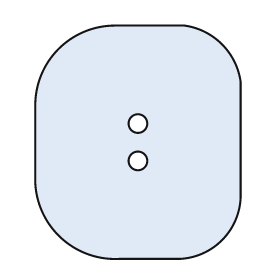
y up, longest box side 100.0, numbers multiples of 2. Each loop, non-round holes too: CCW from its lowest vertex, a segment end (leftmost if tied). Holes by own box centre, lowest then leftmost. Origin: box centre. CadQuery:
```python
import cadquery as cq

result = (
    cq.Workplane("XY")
    .moveTo(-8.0, -50.0)
    .lineTo(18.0, -50.0)
    .threePointArc((36.0, -42.0), (44.0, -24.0))
    .lineTo(44.0, 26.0)
    .threePointArc((36.0, 42.0), (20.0, 50.0))
    .lineTo(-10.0, 50.0)
    .threePointArc((-34.0, 40.0), (-44.0, 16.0))
    .lineTo(-44.0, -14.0)
    .threePointArc((-34.0, -40.0), (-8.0, -50.0))
    .close()
    .moveTo(0.0, -8.0)
    .circle(4.0)
    .moveTo(0.0, 8.0)
    .circle(4.0)
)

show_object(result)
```